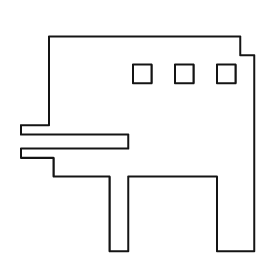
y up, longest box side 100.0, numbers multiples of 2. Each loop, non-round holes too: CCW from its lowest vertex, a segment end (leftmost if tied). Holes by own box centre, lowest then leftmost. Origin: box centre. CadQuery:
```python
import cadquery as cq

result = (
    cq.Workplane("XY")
    .moveTo(-12.0, -46.0)
    .lineTo(-4.0, -46.0)
    .lineTo(-4.0, -14.0)
    .lineTo(34.0, -14.0)
    .lineTo(34.0, -46.0)
    .lineTo(50.0, -46.0)
    .lineTo(50.0, 38.0)
    .lineTo(44.0, 38.0)
    .lineTo(44.0, 46.0)
    .lineTo(-38.0, 46.0)
    .lineTo(-38.0, 8.0)
    .lineTo(-50.0, 8.0)
    .lineTo(-50.0, 4.0)
    .lineTo(-4.0, 4.0)
    .lineTo(-4.0, -2.0)
    .lineTo(-50.0, -2.0)
    .lineTo(-50.0, -6.0)
    .lineTo(-36.0, -6.0)
    .lineTo(-36.0, -14.0)
    .lineTo(-12.0, -14.0)
    .close()
    .moveTo(-2.0, 26.0)
    .lineTo(6.0, 26.0)
    .lineTo(6.0, 34.0)
    .lineTo(-2.0, 34.0)
    .close()
    .moveTo(16.0, 26.0)
    .lineTo(24.0, 26.0)
    .lineTo(24.0, 34.0)
    .lineTo(16.0, 34.0)
    .close()
    .moveTo(34.0, 26.0)
    .lineTo(42.0, 26.0)
    .lineTo(42.0, 34.0)
    .lineTo(34.0, 34.0)
    .close()
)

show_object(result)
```